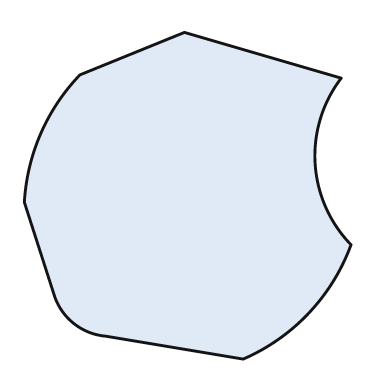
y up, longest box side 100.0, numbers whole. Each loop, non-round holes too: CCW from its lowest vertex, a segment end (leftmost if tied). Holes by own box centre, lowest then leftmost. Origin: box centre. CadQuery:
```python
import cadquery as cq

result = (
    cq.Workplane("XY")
    .moveTo(17.0, -50.0)
    .threePointArc((37.0, -36.0), (50.0, -15.0))
    .threePointArc((39.0, 10.0), (47.0, 36.0))
    .lineTo(-1.0, 50.0)
    .lineTo(-33.0, 37.0)
    .threePointArc((-45.0, 19.0), (-50.0, -2.0))
    .lineTo(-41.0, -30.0)
    .threePointArc((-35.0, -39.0), (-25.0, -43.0))
    .close()
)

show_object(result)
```